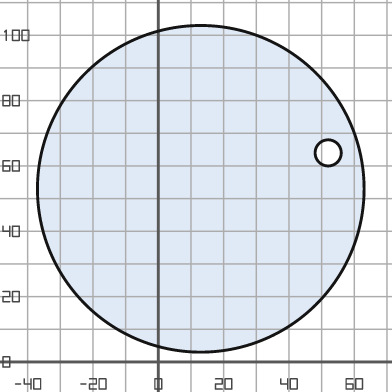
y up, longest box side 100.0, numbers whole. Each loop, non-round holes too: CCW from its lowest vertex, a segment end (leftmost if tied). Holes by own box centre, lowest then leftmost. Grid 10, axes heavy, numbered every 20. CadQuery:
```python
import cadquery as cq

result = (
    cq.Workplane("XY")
    .moveTo(13.0, 53.0)
    .circle(50.0)
    .moveTo(52.0, 64.0)
    .circle(4.0)
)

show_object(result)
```